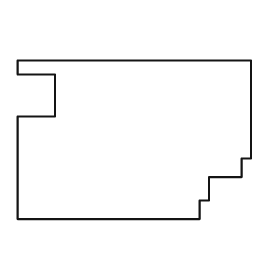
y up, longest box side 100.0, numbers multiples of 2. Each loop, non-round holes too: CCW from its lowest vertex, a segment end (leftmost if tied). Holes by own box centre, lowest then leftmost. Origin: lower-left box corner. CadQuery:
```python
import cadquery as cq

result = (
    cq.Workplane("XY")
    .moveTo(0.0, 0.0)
    .lineTo(78.0, 0.0)
    .lineTo(78.0, 8.0)
    .lineTo(82.0, 8.0)
    .lineTo(82.0, 18.0)
    .lineTo(96.0, 18.0)
    .lineTo(96.0, 26.0)
    .lineTo(100.0, 26.0)
    .lineTo(100.0, 68.0)
    .lineTo(0.0, 68.0)
    .lineTo(0.0, 62.0)
    .lineTo(16.0, 62.0)
    .lineTo(16.0, 44.0)
    .lineTo(0.0, 44.0)
    .close()
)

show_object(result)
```